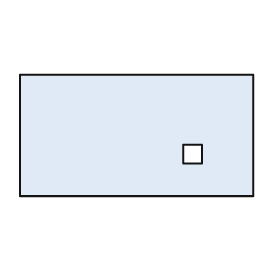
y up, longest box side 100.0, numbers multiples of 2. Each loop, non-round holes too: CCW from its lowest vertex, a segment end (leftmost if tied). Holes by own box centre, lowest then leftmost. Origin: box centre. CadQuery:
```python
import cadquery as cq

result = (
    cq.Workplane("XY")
    .moveTo(-50.0, -26.0)
    .lineTo(50.0, -26.0)
    .lineTo(50.0, 26.0)
    .lineTo(-50.0, 26.0)
    .close()
    .moveTo(20.0, -12.0)
    .lineTo(28.0, -12.0)
    .lineTo(28.0, -4.0)
    .lineTo(20.0, -4.0)
    .close()
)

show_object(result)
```